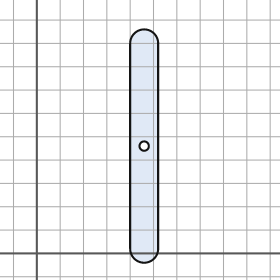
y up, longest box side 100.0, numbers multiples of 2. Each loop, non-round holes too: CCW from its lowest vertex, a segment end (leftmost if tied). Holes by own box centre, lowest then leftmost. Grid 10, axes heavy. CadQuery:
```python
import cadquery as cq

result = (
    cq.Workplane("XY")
    .moveTo(40.0, 2.0)
    .threePointArc((46.0, -4.0), (52.0, 2.0))
    .lineTo(52.0, 90.0)
    .threePointArc((46.0, 96.0), (40.0, 90.0))
    .close()
    .moveTo(46.0, 46.0)
    .circle(2.0)
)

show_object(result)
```